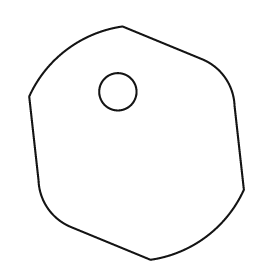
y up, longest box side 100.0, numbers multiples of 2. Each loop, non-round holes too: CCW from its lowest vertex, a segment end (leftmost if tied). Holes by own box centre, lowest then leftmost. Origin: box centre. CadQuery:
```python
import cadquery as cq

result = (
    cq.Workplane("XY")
    .moveTo(6.0, -50.0)
    .threePointArc((30.0, -40.0), (46.0, -20.0))
    .lineTo(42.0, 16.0)
    .threePointArc((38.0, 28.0), (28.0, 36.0))
    .lineTo(-6.0, 50.0)
    .threePointArc((-30.0, 40.0), (-46.0, 20.0))
    .lineTo(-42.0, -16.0)
    .threePointArc((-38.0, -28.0), (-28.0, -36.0))
    .close()
    .moveTo(-8.0, 22.0)
    .circle(8.0)
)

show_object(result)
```